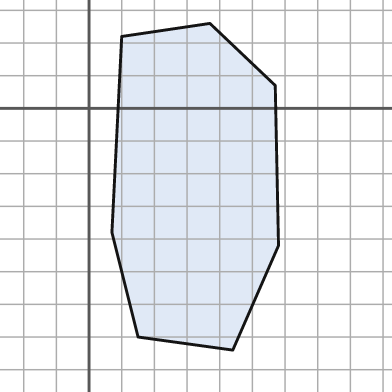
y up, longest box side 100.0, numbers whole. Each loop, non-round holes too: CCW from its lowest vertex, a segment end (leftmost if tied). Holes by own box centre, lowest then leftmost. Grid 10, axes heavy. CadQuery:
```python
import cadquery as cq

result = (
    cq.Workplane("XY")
    .moveTo(44.0, -74.0)
    .lineTo(58.0, -42.0)
    .lineTo(57.0, 7.0)
    .lineTo(37.0, 26.0)
    .lineTo(10.0, 22.0)
    .lineTo(7.0, -38.0)
    .lineTo(15.0, -70.0)
    .close()
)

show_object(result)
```